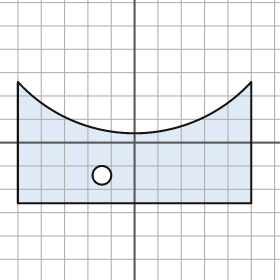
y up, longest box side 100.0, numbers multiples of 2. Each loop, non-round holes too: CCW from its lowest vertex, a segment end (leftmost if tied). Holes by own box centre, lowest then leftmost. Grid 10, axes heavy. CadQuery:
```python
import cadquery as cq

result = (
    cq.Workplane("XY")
    .moveTo(-50.0, -26.0)
    .lineTo(50.0, -26.0)
    .lineTo(50.0, 26.0)
    .threePointArc((0.0, 4.0), (-50.0, 26.0))
    .close()
    .moveTo(-14.0, -14.0)
    .circle(4.0)
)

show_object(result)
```